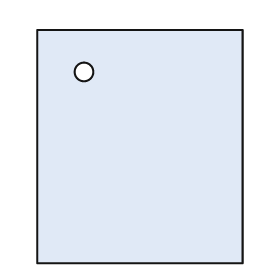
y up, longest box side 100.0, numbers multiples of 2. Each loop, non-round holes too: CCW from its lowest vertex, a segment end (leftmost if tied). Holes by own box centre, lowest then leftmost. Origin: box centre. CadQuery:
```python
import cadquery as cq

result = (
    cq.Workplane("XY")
    .moveTo(-44.0, -50.0)
    .lineTo(44.0, -50.0)
    .lineTo(44.0, 50.0)
    .lineTo(-44.0, 50.0)
    .close()
    .moveTo(-24.0, 32.0)
    .circle(4.0)
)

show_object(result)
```